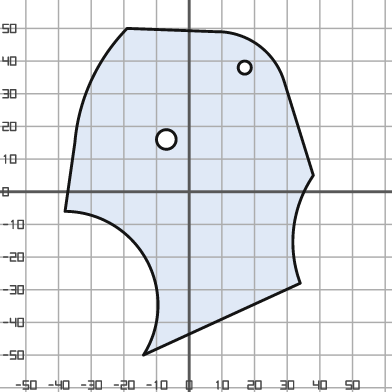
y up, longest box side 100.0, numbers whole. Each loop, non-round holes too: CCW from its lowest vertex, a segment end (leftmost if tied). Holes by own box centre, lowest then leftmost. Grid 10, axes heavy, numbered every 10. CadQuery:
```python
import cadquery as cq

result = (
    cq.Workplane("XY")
    .moveTo(-14.0, -50.0)
    .lineTo(34.0, -28.0)
    .threePointArc((32.0, -11.0), (38.0, 5.0))
    .lineTo(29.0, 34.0)
    .threePointArc((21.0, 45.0), (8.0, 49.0))
    .lineTo(-19.0, 50.0)
    .threePointArc((-30.0, 34.0), (-35.0, 15.0))
    .lineTo(-38.0, -6.0)
    .threePointArc((-13.0, -21.0), (-14.0, -50.0))
    .close()
    .moveTo(-7.0, 16.0)
    .circle(3.0)
    .moveTo(17.0, 38.0)
    .circle(2.0)
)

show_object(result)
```